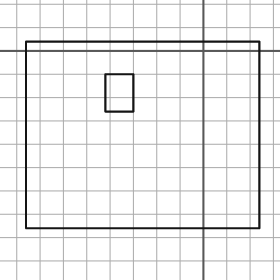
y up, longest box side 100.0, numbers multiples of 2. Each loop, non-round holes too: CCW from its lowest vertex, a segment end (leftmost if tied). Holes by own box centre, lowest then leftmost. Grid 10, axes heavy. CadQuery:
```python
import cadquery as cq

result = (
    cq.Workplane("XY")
    .moveTo(-76.0, -76.0)
    .lineTo(24.0, -76.0)
    .lineTo(24.0, 4.0)
    .lineTo(-76.0, 4.0)
    .close()
    .moveTo(-42.0, -26.0)
    .lineTo(-30.0, -26.0)
    .lineTo(-30.0, -10.0)
    .lineTo(-42.0, -10.0)
    .close()
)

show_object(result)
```